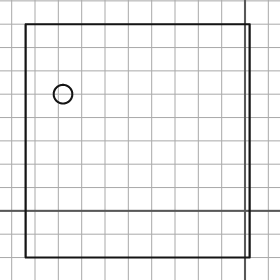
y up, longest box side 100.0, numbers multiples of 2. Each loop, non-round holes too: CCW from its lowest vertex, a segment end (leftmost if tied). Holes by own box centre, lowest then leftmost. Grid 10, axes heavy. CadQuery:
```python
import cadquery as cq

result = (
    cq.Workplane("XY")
    .moveTo(-94.0, -20.0)
    .lineTo(2.0, -20.0)
    .lineTo(2.0, 80.0)
    .lineTo(-94.0, 80.0)
    .close()
    .moveTo(-78.0, 50.0)
    .circle(4.0)
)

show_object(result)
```